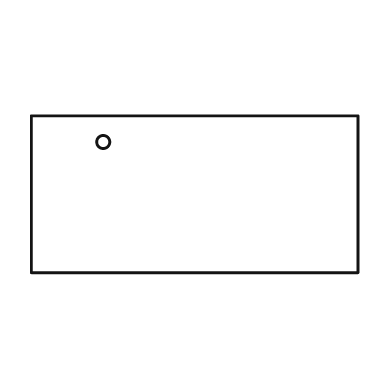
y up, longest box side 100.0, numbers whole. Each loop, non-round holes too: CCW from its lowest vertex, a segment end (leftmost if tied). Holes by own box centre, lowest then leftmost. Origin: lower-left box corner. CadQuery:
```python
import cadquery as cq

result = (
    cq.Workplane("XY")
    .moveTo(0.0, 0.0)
    .lineTo(100.0, 0.0)
    .lineTo(100.0, 48.0)
    .lineTo(0.0, 48.0)
    .close()
    .moveTo(22.0, 40.0)
    .circle(2.0)
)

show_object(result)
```